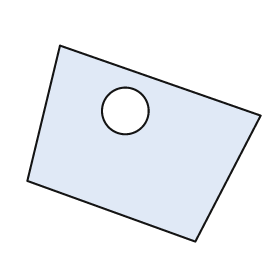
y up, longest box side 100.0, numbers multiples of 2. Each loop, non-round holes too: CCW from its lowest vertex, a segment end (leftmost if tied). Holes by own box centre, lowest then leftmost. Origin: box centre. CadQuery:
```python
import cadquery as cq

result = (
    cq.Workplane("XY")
    .moveTo(22.0, -42.0)
    .lineTo(50.0, 12.0)
    .lineTo(-36.0, 42.0)
    .lineTo(-50.0, -16.0)
    .close()
    .moveTo(-8.0, 14.0)
    .circle(10.0)
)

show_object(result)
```